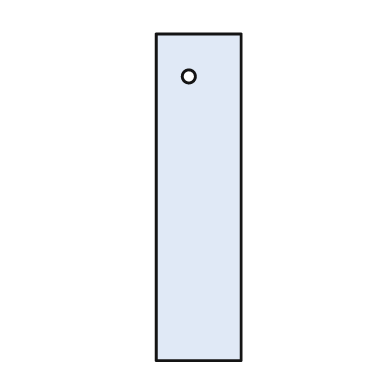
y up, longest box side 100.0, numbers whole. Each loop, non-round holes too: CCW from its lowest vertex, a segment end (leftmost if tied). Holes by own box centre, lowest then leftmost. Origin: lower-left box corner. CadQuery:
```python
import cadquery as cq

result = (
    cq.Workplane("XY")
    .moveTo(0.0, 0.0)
    .lineTo(26.0, 0.0)
    .lineTo(26.0, 100.0)
    .lineTo(0.0, 100.0)
    .close()
    .moveTo(10.0, 87.0)
    .circle(2.0)
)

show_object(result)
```